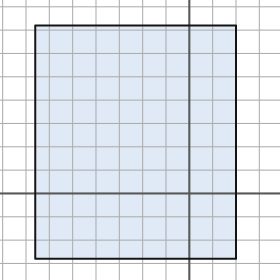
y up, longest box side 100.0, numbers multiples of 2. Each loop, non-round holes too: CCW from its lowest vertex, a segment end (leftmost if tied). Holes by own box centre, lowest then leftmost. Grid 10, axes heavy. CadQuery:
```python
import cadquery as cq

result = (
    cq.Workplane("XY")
    .moveTo(-66.0, -28.0)
    .lineTo(20.0, -28.0)
    .lineTo(20.0, 72.0)
    .lineTo(-66.0, 72.0)
    .close()
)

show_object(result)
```